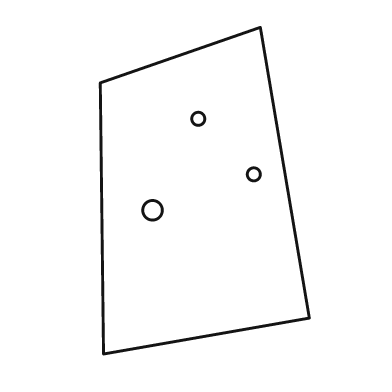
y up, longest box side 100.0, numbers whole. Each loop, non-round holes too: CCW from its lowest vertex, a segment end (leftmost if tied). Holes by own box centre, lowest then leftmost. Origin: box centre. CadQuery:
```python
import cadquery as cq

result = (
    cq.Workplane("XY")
    .moveTo(-31.0, -50.0)
    .lineTo(32.0, -39.0)
    .lineTo(17.0, 50.0)
    .lineTo(-32.0, 33.0)
    .close()
    .moveTo(-16.0, -6.0)
    .circle(3.0)
    .moveTo(15.0, 5.0)
    .circle(2.0)
    .moveTo(-2.0, 22.0)
    .circle(2.0)
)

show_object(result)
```